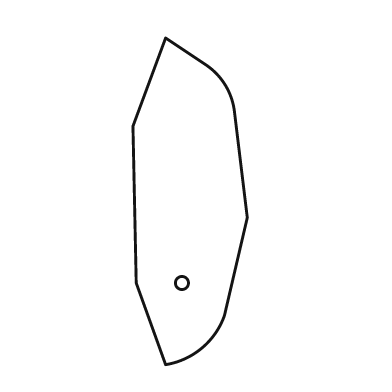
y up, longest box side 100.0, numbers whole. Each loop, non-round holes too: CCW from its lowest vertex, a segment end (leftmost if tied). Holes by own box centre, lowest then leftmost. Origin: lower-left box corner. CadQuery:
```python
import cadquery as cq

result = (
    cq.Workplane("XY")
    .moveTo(10.0, 0.0)
    .threePointArc((21.0, 5.0), (28.0, 15.0))
    .lineTo(35.0, 45.0)
    .lineTo(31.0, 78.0)
    .threePointArc((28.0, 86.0), (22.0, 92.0))
    .lineTo(10.0, 100.0)
    .lineTo(0.0, 73.0)
    .lineTo(1.0, 25.0)
    .close()
    .moveTo(15.0, 25.0)
    .circle(2.0)
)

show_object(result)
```